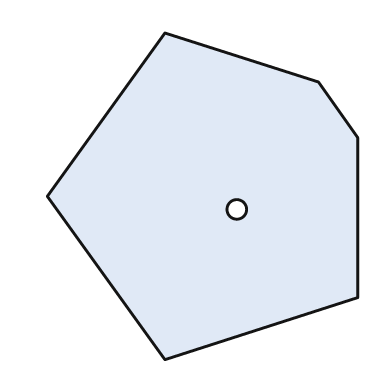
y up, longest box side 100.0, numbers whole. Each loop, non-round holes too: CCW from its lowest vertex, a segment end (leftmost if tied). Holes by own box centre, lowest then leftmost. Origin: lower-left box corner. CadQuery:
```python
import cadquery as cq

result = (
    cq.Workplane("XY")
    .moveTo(36.0, 0.0)
    .lineTo(95.0, 19.0)
    .lineTo(95.0, 68.0)
    .lineTo(83.0, 85.0)
    .lineTo(36.0, 100.0)
    .lineTo(0.0, 50.0)
    .close()
    .moveTo(58.0, 46.0)
    .circle(3.0)
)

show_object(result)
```